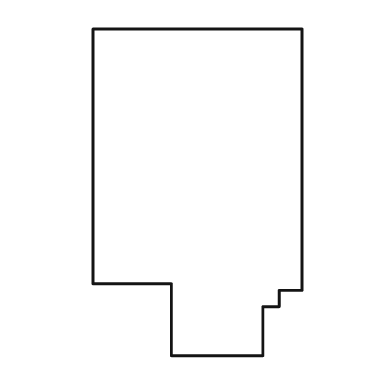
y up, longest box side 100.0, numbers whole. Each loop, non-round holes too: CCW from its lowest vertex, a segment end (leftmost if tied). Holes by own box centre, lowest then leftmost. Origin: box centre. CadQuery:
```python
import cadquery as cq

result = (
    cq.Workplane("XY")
    .moveTo(-8.0, -50.0)
    .lineTo(20.0, -50.0)
    .lineTo(20.0, -35.0)
    .lineTo(25.0, -35.0)
    .lineTo(25.0, -30.0)
    .lineTo(32.0, -30.0)
    .lineTo(32.0, 50.0)
    .lineTo(-32.0, 50.0)
    .lineTo(-32.0, -28.0)
    .lineTo(-8.0, -28.0)
    .close()
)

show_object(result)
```